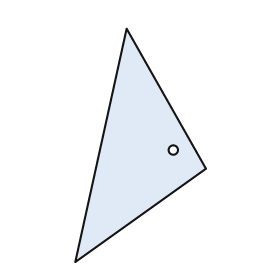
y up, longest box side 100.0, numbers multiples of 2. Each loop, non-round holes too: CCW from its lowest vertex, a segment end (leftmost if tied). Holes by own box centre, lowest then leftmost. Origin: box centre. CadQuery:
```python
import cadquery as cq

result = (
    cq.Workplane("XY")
    .moveTo(-28.0, -50.0)
    .lineTo(28.0, -10.0)
    .lineTo(-6.0, 50.0)
    .close()
    .moveTo(14.0, -2.0)
    .circle(2.0)
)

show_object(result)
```